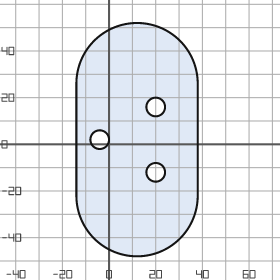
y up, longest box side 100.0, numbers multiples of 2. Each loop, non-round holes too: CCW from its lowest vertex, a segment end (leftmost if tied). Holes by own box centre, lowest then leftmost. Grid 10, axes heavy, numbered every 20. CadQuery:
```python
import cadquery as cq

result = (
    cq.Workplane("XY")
    .moveTo(-14.0, -22.0)
    .threePointArc((12.0, -48.0), (38.0, -22.0))
    .lineTo(38.0, 26.0)
    .threePointArc((12.0, 52.0), (-14.0, 26.0))
    .close()
    .moveTo(20.0, -12.0)
    .circle(4.0)
    .moveTo(-4.0, 2.0)
    .circle(4.0)
    .moveTo(20.0, 16.0)
    .circle(4.0)
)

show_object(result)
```